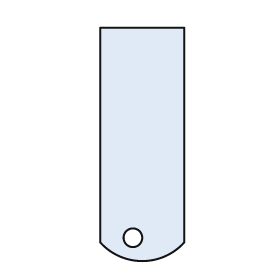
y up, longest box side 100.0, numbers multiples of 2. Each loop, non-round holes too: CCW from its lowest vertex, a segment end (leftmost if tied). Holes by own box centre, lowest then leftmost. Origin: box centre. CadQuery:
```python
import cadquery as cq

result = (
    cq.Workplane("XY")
    .moveTo(-18.0, -42.0)
    .threePointArc((0.0, -50.0), (18.0, -42.0))
    .lineTo(18.0, 50.0)
    .lineTo(-18.0, 50.0)
    .close()
    .moveTo(-4.0, -40.0)
    .circle(4.0)
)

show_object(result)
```